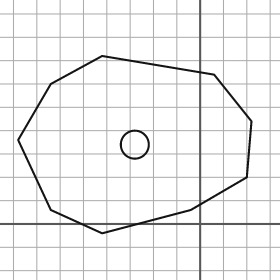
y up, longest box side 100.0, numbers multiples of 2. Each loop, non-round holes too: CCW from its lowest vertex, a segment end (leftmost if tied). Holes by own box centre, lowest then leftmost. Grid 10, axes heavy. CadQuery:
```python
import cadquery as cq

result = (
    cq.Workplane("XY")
    .moveTo(-42.0, -4.0)
    .lineTo(-4.0, 6.0)
    .lineTo(20.0, 20.0)
    .lineTo(22.0, 44.0)
    .lineTo(6.0, 64.0)
    .lineTo(-42.0, 72.0)
    .lineTo(-64.0, 60.0)
    .lineTo(-78.0, 36.0)
    .lineTo(-64.0, 6.0)
    .close()
    .moveTo(-28.0, 34.0)
    .circle(6.0)
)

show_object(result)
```